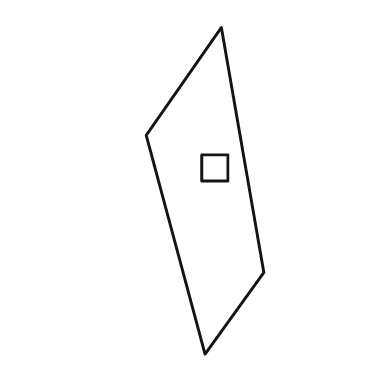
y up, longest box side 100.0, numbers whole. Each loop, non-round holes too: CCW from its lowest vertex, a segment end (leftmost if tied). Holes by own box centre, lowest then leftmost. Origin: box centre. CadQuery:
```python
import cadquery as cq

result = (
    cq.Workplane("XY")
    .moveTo(0.0, -50.0)
    .lineTo(18.0, -25.0)
    .lineTo(5.0, 50.0)
    .lineTo(-18.0, 17.0)
    .close()
    .moveTo(-1.0, 3.0)
    .lineTo(7.0, 3.0)
    .lineTo(7.0, 11.0)
    .lineTo(-1.0, 11.0)
    .close()
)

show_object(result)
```